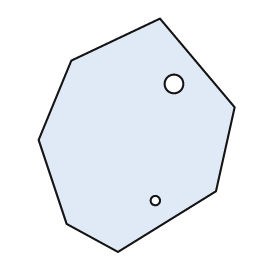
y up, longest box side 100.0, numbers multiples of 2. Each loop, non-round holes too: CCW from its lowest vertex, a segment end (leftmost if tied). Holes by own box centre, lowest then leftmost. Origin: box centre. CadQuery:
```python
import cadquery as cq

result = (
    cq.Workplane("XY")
    .moveTo(-8.0, -50.0)
    .lineTo(34.0, -24.0)
    .lineTo(42.0, 12.0)
    .lineTo(10.0, 50.0)
    .lineTo(-28.0, 32.0)
    .lineTo(-42.0, -2.0)
    .lineTo(-30.0, -38.0)
    .close()
    .moveTo(8.0, -28.0)
    .circle(2.0)
    .moveTo(16.0, 22.0)
    .circle(4.0)
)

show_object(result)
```